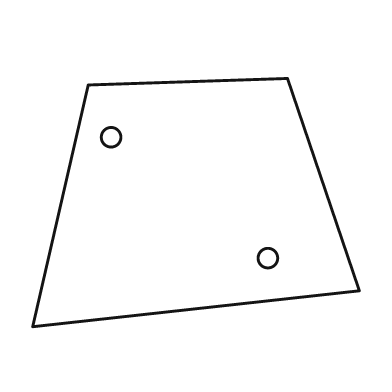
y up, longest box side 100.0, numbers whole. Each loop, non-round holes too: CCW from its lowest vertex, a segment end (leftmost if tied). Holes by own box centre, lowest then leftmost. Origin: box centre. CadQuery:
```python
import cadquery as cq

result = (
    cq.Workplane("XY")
    .moveTo(-50.0, -38.0)
    .lineTo(50.0, -27.0)
    .lineTo(28.0, 38.0)
    .lineTo(-33.0, 36.0)
    .close()
    .moveTo(22.0, -17.0)
    .circle(3.0)
    .moveTo(-26.0, 20.0)
    .circle(3.0)
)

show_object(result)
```